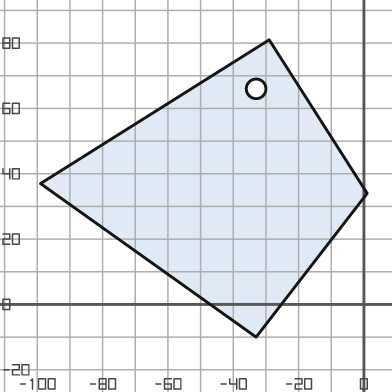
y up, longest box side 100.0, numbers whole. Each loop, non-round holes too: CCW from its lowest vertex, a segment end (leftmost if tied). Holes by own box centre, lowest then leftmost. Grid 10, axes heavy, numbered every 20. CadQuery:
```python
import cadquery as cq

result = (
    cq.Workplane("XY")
    .moveTo(-33.0, -10.0)
    .lineTo(1.0, 34.0)
    .lineTo(-29.0, 81.0)
    .lineTo(-99.0, 37.0)
    .close()
    .moveTo(-33.0, 66.0)
    .circle(3.0)
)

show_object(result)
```